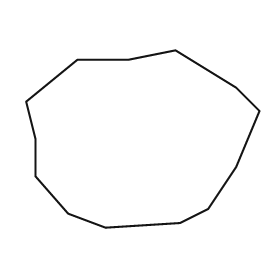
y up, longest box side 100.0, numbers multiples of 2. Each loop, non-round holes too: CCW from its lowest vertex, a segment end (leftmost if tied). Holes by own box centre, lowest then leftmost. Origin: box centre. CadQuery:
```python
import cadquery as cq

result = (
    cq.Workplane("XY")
    .moveTo(-16.0, -38.0)
    .lineTo(16.0, -36.0)
    .lineTo(28.0, -30.0)
    .lineTo(40.0, -12.0)
    .lineTo(50.0, 12.0)
    .lineTo(40.0, 22.0)
    .lineTo(14.0, 38.0)
    .lineTo(-6.0, 34.0)
    .lineTo(-28.0, 34.0)
    .lineTo(-50.0, 16.0)
    .lineTo(-46.0, 0.0)
    .lineTo(-46.0, -16.0)
    .lineTo(-32.0, -32.0)
    .close()
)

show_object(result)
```